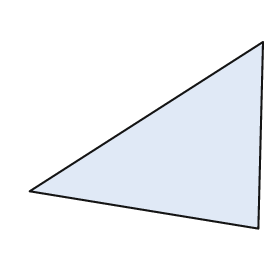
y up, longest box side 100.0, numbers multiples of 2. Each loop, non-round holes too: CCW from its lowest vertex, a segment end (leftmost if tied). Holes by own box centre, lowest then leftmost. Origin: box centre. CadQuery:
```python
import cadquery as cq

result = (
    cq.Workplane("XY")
    .moveTo(48.0, -40.0)
    .lineTo(50.0, 40.0)
    .lineTo(-50.0, -24.0)
    .close()
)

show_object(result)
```